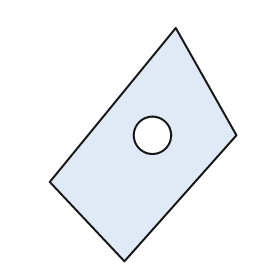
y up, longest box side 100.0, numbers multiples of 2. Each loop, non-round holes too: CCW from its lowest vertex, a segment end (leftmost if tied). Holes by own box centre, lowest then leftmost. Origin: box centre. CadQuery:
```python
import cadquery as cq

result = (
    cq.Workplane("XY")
    .moveTo(-8.0, -50.0)
    .lineTo(40.0, 4.0)
    .lineTo(14.0, 50.0)
    .lineTo(-40.0, -16.0)
    .close()
    .moveTo(4.0, 4.0)
    .circle(8.0)
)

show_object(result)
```